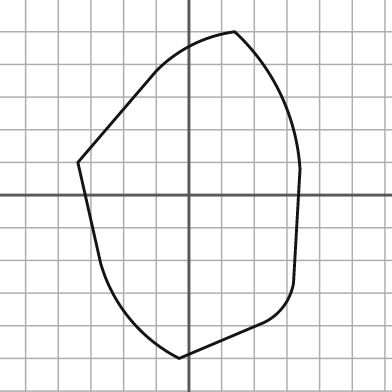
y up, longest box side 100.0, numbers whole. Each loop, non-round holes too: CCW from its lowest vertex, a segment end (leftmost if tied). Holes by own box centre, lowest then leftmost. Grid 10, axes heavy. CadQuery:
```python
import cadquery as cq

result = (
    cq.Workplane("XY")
    .moveTo(-3.0, -50.0)
    .lineTo(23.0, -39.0)
    .threePointArc((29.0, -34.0), (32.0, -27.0))
    .lineTo(34.0, 8.0)
    .threePointArc((28.0, 31.0), (14.0, 50.0))
    .threePointArc((1.0, 46.0), (-10.0, 38.0))
    .lineTo(-34.0, 10.0)
    .lineTo(-27.0, -21.0)
    .threePointArc((-18.0, -38.0), (-3.0, -50.0))
    .close()
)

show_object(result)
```